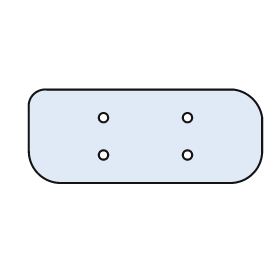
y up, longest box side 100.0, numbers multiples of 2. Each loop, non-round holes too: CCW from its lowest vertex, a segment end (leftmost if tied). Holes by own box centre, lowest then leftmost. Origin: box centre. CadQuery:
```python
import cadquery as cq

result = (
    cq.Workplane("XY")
    .moveTo(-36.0, -20.0)
    .lineTo(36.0, -20.0)
    .threePointArc((46.0, -16.0), (50.0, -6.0))
    .lineTo(50.0, 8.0)
    .threePointArc((46.0, 16.0), (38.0, 20.0))
    .lineTo(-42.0, 20.0)
    .threePointArc((-48.0, 18.0), (-50.0, 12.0))
    .lineTo(-50.0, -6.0)
    .threePointArc((-46.0, -16.0), (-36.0, -20.0))
    .close()
    .moveTo(-18.0, -8.0)
    .circle(2.0)
    .moveTo(18.0, -8.0)
    .circle(2.0)
    .moveTo(-18.0, 8.0)
    .circle(2.0)
    .moveTo(18.0, 8.0)
    .circle(2.0)
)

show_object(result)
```